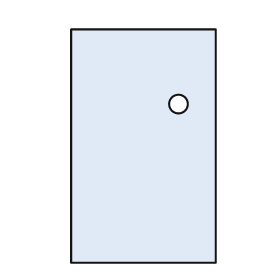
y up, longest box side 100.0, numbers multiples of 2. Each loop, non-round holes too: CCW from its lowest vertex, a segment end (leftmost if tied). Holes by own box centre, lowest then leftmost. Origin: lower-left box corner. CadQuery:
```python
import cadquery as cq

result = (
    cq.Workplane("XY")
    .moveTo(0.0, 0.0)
    .lineTo(62.0, 0.0)
    .lineTo(62.0, 100.0)
    .lineTo(0.0, 100.0)
    .close()
    .moveTo(46.0, 68.0)
    .circle(4.0)
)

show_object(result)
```